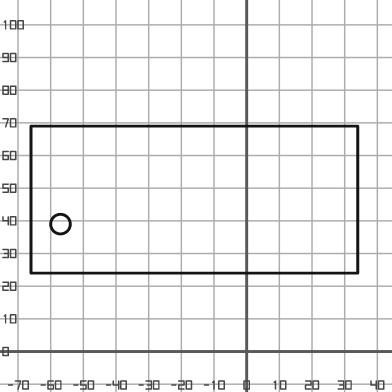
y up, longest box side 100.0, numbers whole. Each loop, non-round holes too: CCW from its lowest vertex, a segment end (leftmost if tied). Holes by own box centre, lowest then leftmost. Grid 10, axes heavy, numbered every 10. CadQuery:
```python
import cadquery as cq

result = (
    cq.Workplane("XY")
    .moveTo(-66.0, 24.0)
    .lineTo(34.0, 24.0)
    .lineTo(34.0, 69.0)
    .lineTo(-66.0, 69.0)
    .close()
    .moveTo(-57.0, 39.0)
    .circle(3.0)
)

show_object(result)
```